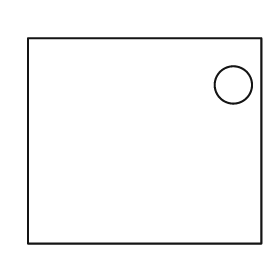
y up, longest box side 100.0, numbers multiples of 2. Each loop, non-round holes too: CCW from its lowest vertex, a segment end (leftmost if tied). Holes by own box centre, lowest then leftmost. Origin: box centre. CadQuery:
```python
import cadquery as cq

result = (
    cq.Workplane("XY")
    .moveTo(-50.0, -44.0)
    .lineTo(50.0, -44.0)
    .lineTo(50.0, 44.0)
    .lineTo(-50.0, 44.0)
    .close()
    .moveTo(38.0, 24.0)
    .circle(8.0)
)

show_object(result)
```